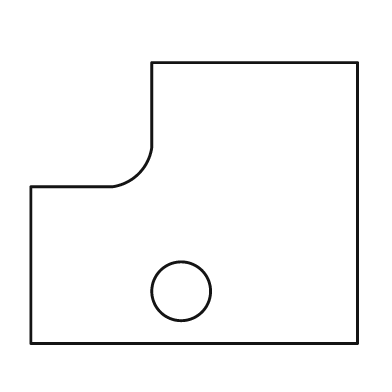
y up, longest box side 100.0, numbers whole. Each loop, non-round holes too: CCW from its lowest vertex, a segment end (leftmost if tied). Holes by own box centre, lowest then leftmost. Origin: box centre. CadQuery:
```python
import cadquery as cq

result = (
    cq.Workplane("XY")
    .moveTo(-50.0, -43.0)
    .lineTo(50.0, -43.0)
    .lineTo(50.0, 43.0)
    .lineTo(-13.0, 43.0)
    .lineTo(-13.0, 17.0)
    .threePointArc((-17.0, 9.0), (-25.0, 5.0))
    .lineTo(-50.0, 5.0)
    .close()
    .moveTo(-4.0, -27.0)
    .circle(9.0)
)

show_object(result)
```